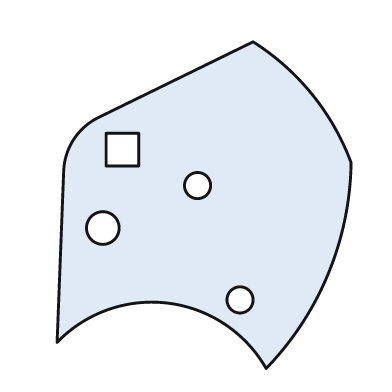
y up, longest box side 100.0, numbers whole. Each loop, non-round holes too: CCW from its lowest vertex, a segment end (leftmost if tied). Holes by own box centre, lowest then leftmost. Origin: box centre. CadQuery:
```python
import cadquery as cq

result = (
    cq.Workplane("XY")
    .moveTo(19.0, -50.0)
    .threePointArc((38.0, -21.0), (45.0, 13.0))
    .threePointArc((33.0, 34.0), (15.0, 50.0))
    .lineTo(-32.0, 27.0)
    .threePointArc((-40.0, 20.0), (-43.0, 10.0))
    .lineTo(-45.0, -42.0)
    .threePointArc((-11.0, -30.0), (19.0, -50.0))
    .close()
    .moveTo(11.0, -29.0)
    .circle(4.0)
    .moveTo(-31.0, -7.0)
    .circle(5.0)
    .moveTo(-2.0, 6.0)
    .circle(4.0)
    .moveTo(-30.0, 12.0)
    .lineTo(-20.0, 12.0)
    .lineTo(-20.0, 22.0)
    .lineTo(-30.0, 22.0)
    .close()
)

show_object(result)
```